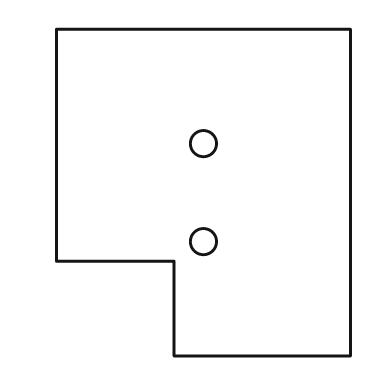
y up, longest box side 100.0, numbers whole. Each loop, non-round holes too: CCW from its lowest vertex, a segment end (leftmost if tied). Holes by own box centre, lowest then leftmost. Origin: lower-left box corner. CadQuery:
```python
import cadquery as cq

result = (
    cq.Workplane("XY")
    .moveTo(36.0, 0.0)
    .lineTo(90.0, 0.0)
    .lineTo(90.0, 100.0)
    .lineTo(0.0, 100.0)
    .lineTo(0.0, 29.0)
    .lineTo(36.0, 29.0)
    .close()
    .moveTo(45.0, 35.0)
    .circle(4.0)
    .moveTo(45.0, 65.0)
    .circle(4.0)
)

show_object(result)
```